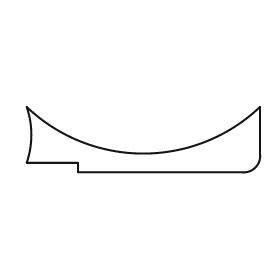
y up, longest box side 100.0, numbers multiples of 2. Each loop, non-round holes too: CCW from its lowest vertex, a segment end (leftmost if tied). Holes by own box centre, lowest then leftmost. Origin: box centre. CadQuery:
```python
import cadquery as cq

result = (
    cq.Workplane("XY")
    .moveTo(-28.0, -14.0)
    .lineTo(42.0, -14.0)
    .threePointArc((48.0, -12.0), (50.0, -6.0))
    .lineTo(50.0, 14.0)
    .threePointArc((0.0, -6.0), (-50.0, 14.0))
    .threePointArc((-48.0, 2.0), (-50.0, -10.0))
    .lineTo(-28.0, -10.0)
    .close()
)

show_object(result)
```